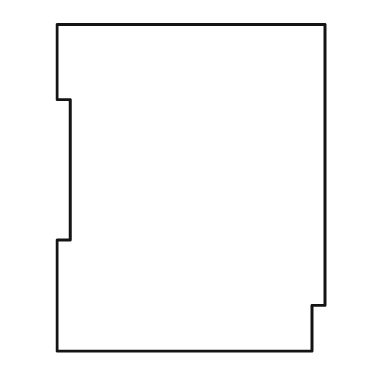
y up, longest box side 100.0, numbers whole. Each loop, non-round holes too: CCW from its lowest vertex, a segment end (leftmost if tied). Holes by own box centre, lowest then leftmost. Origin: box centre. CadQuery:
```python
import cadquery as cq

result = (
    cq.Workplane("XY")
    .moveTo(-41.0, -50.0)
    .lineTo(37.0, -50.0)
    .lineTo(37.0, -36.0)
    .lineTo(41.0, -36.0)
    .lineTo(41.0, 50.0)
    .lineTo(-41.0, 50.0)
    .lineTo(-41.0, 27.0)
    .lineTo(-37.0, 27.0)
    .lineTo(-37.0, -16.0)
    .lineTo(-41.0, -16.0)
    .close()
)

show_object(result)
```